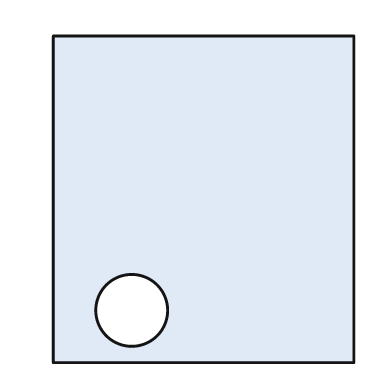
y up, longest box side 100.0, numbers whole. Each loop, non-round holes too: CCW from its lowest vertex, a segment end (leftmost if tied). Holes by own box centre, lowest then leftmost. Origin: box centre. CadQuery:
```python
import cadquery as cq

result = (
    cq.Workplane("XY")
    .moveTo(-46.0, -50.0)
    .lineTo(46.0, -50.0)
    .lineTo(46.0, 50.0)
    .lineTo(-46.0, 50.0)
    .close()
    .moveTo(-22.0, -34.0)
    .circle(11.0)
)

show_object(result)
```